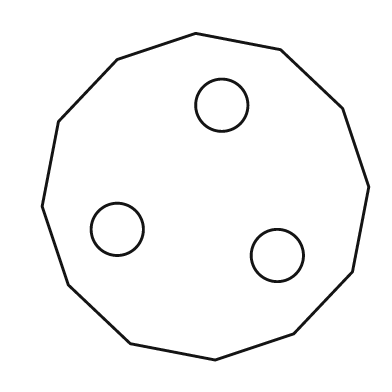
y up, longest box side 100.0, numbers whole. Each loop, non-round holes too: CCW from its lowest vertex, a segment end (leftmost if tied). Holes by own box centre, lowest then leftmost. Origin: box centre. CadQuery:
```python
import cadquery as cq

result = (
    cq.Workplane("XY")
    .moveTo(3.0, -50.0)
    .lineTo(27.0, -42.0)
    .lineTo(45.0, -23.0)
    .lineTo(50.0, 3.0)
    .lineTo(42.0, 27.0)
    .lineTo(23.0, 45.0)
    .lineTo(-3.0, 50.0)
    .lineTo(-27.0, 42.0)
    .lineTo(-45.0, 23.0)
    .lineTo(-50.0, -3.0)
    .lineTo(-42.0, -27.0)
    .lineTo(-23.0, -45.0)
    .close()
    .moveTo(22.0, -18.0)
    .circle(8.0)
    .moveTo(-27.0, -10.0)
    .circle(8.0)
    .moveTo(5.0, 28.0)
    .circle(8.0)
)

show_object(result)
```